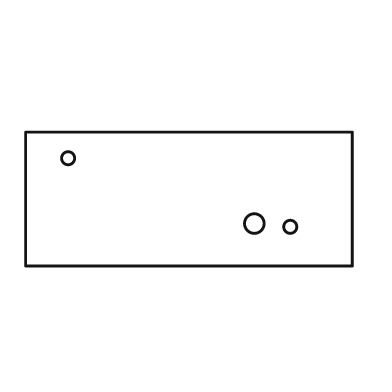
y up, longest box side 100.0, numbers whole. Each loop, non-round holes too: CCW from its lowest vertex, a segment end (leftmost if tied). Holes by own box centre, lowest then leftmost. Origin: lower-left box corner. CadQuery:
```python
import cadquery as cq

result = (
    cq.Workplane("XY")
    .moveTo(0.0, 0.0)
    .lineTo(100.0, 0.0)
    .lineTo(100.0, 41.0)
    .lineTo(0.0, 41.0)
    .close()
    .moveTo(81.0, 12.0)
    .circle(2.0)
    .moveTo(70.0, 13.0)
    .circle(3.0)
    .moveTo(13.0, 33.0)
    .circle(2.0)
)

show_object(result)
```